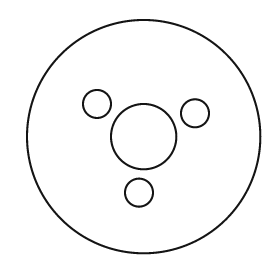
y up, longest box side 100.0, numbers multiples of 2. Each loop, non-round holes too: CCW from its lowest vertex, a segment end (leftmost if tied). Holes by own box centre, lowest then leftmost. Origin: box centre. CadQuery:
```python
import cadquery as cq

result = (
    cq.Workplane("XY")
    .moveTo(0.0, 0.0)
    .circle(50.0)
    .moveTo(-2.0, -24.0)
    .circle(6.0)
    .moveTo(0.0, 0.0)
    .circle(14.0)
    .moveTo(22.0, 10.0)
    .circle(6.0)
    .moveTo(-20.0, 14.0)
    .circle(6.0)
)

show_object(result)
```